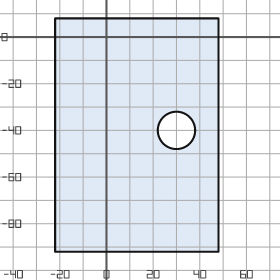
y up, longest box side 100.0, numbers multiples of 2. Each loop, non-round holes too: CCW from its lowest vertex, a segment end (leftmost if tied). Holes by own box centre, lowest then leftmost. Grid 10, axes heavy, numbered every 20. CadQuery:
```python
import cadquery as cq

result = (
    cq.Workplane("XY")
    .moveTo(-22.0, -92.0)
    .lineTo(48.0, -92.0)
    .lineTo(48.0, 8.0)
    .lineTo(-22.0, 8.0)
    .close()
    .moveTo(30.0, -40.0)
    .circle(8.0)
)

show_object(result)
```